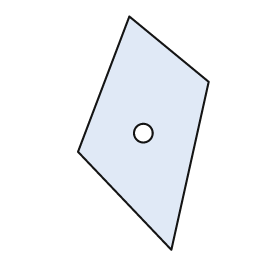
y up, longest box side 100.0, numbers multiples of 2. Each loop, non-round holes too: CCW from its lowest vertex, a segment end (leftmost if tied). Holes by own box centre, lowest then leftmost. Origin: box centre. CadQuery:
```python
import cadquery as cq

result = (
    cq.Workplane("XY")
    .moveTo(12.0, -50.0)
    .lineTo(28.0, 22.0)
    .lineTo(-6.0, 50.0)
    .lineTo(-28.0, -8.0)
    .close()
    .moveTo(0.0, 0.0)
    .circle(4.0)
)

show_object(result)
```